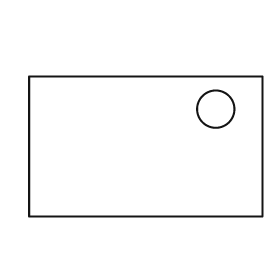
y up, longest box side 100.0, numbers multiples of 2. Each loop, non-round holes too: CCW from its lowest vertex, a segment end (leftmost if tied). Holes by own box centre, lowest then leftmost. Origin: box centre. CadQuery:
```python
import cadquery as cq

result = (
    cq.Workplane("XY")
    .moveTo(-50.0, -30.0)
    .lineTo(50.0, -30.0)
    .lineTo(50.0, 30.0)
    .lineTo(-50.0, 30.0)
    .close()
    .moveTo(30.0, 16.0)
    .circle(8.0)
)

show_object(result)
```